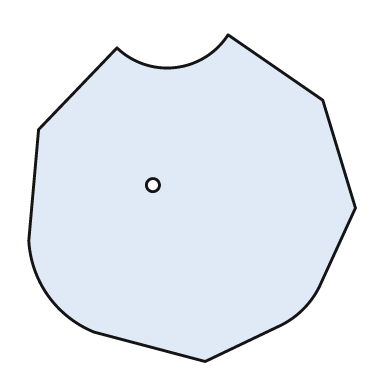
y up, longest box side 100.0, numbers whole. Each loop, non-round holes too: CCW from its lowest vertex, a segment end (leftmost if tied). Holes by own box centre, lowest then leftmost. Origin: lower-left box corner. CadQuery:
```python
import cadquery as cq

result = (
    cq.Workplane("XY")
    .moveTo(54.0, 0.0)
    .lineTo(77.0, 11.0)
    .threePointArc((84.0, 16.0), (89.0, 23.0))
    .lineTo(100.0, 47.0)
    .lineTo(90.0, 80.0)
    .lineTo(61.0, 100.0)
    .threePointArc((45.0, 90.0), (27.0, 96.0))
    .lineTo(3.0, 71.0)
    .lineTo(0.0, 37.0)
    .threePointArc((6.0, 20.0), (20.0, 9.0))
    .close()
    .moveTo(38.0, 54.0)
    .circle(2.0)
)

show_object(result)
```